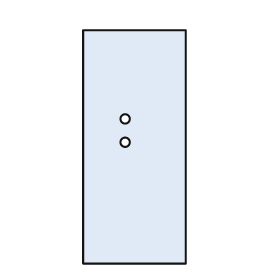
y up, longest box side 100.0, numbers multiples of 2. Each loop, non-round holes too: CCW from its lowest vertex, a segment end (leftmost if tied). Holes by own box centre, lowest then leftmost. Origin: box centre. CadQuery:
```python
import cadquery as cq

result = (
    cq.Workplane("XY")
    .moveTo(-22.0, -50.0)
    .lineTo(22.0, -50.0)
    .lineTo(22.0, 50.0)
    .lineTo(-22.0, 50.0)
    .close()
    .moveTo(-4.0, 2.0)
    .circle(2.0)
    .moveTo(-4.0, 12.0)
    .circle(2.0)
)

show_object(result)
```